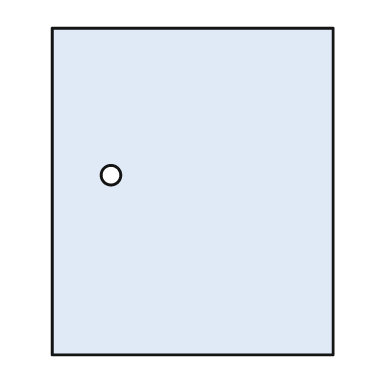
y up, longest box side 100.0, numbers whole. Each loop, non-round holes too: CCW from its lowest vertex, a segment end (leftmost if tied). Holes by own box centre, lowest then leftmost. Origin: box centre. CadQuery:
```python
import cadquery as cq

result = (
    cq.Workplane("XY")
    .moveTo(-43.0, -50.0)
    .lineTo(43.0, -50.0)
    .lineTo(43.0, 50.0)
    .lineTo(-43.0, 50.0)
    .close()
    .moveTo(-25.0, 5.0)
    .circle(3.0)
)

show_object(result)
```